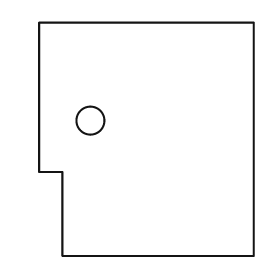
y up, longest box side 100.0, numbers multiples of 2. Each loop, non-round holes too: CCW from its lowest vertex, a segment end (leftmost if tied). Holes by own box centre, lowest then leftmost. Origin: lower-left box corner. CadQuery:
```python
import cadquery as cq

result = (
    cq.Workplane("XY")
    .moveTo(10.0, 0.0)
    .lineTo(92.0, 0.0)
    .lineTo(92.0, 100.0)
    .lineTo(0.0, 100.0)
    .lineTo(0.0, 36.0)
    .lineTo(10.0, 36.0)
    .close()
    .moveTo(22.0, 58.0)
    .circle(6.0)
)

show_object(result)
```